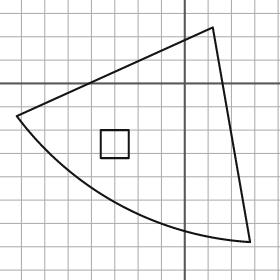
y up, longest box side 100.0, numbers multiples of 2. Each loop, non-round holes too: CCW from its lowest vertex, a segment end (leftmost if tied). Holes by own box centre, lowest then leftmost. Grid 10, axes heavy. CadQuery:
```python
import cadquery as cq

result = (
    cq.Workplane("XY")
    .moveTo(28.0, -68.0)
    .lineTo(12.0, 24.0)
    .lineTo(-72.0, -14.0)
    .threePointArc((-28.0, -52.0), (28.0, -68.0))
    .close()
    .moveTo(-36.0, -32.0)
    .lineTo(-24.0, -32.0)
    .lineTo(-24.0, -20.0)
    .lineTo(-36.0, -20.0)
    .close()
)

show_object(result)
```